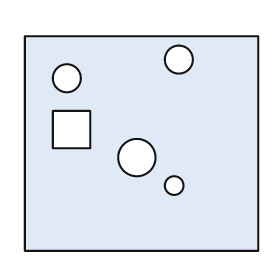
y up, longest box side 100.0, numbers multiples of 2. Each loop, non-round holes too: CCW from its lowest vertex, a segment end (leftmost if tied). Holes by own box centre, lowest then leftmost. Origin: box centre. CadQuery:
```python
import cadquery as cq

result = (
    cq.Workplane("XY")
    .moveTo(-50.0, -46.0)
    .lineTo(50.0, -46.0)
    .lineTo(50.0, 46.0)
    .lineTo(-50.0, 46.0)
    .close()
    .moveTo(14.0, -18.0)
    .circle(4.0)
    .moveTo(-2.0, -6.0)
    .circle(8.0)
    .moveTo(-38.0, -2.0)
    .lineTo(-22.0, -2.0)
    .lineTo(-22.0, 14.0)
    .lineTo(-38.0, 14.0)
    .close()
    .moveTo(-32.0, 28.0)
    .circle(6.0)
    .moveTo(16.0, 36.0)
    .circle(6.0)
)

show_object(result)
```